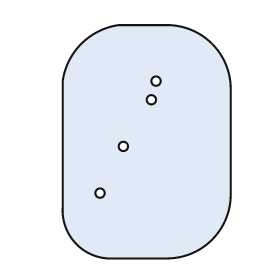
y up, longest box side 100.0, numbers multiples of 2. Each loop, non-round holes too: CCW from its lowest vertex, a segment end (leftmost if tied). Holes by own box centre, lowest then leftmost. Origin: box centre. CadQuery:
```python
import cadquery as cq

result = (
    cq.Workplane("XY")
    .moveTo(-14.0, -50.0)
    .lineTo(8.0, -50.0)
    .threePointArc((28.0, -42.0), (36.0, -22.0))
    .lineTo(36.0, 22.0)
    .threePointArc((28.0, 42.0), (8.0, 50.0))
    .lineTo(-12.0, 50.0)
    .threePointArc((-28.0, 42.0), (-36.0, 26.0))
    .lineTo(-36.0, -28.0)
    .threePointArc((-30.0, -44.0), (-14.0, -50.0))
    .close()
    .moveTo(-20.0, -22.0)
    .circle(2.0)
    .moveTo(-10.0, -2.0)
    .circle(2.0)
    .moveTo(2.0, 18.0)
    .circle(2.0)
    .moveTo(4.0, 26.0)
    .circle(2.0)
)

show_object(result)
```